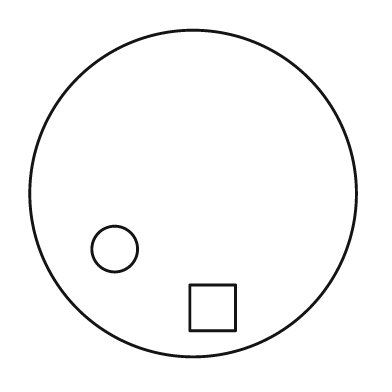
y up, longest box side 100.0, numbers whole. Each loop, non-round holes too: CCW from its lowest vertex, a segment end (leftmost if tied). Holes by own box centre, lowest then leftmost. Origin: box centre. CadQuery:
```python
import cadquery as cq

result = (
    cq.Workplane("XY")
    .moveTo(0.0, 0.0)
    .circle(50.0)
    .moveTo(-1.0, -42.0)
    .lineTo(13.0, -42.0)
    .lineTo(13.0, -28.0)
    .lineTo(-1.0, -28.0)
    .close()
    .moveTo(-24.0, -17.0)
    .circle(7.0)
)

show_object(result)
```